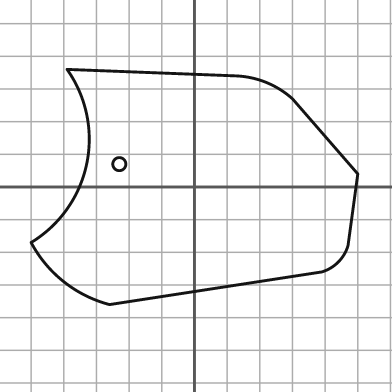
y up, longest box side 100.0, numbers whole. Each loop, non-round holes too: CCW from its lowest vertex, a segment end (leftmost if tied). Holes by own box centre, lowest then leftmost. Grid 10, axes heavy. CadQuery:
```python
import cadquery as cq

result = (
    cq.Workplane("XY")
    .moveTo(-26.0, -36.0)
    .lineTo(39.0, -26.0)
    .threePointArc((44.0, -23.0), (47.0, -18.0))
    .lineTo(50.0, 4.0)
    .lineTo(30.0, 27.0)
    .threePointArc((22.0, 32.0), (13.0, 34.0))
    .lineTo(-39.0, 36.0)
    .threePointArc((-33.0, 7.0), (-50.0, -17.0))
    .threePointArc((-40.0, -29.0), (-26.0, -36.0))
    .close()
    .moveTo(-23.0, 7.0)
    .circle(2.0)
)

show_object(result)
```